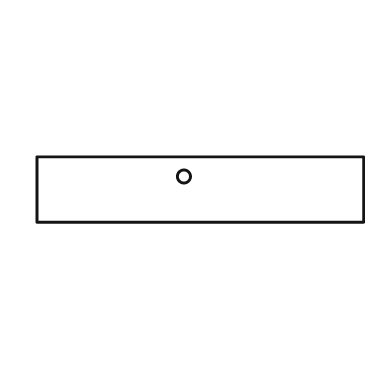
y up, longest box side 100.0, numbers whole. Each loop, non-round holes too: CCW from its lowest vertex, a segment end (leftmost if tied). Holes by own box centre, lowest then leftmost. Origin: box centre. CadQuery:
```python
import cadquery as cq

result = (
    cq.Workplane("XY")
    .moveTo(-50.0, -10.0)
    .lineTo(50.0, -10.0)
    .lineTo(50.0, 10.0)
    .lineTo(-50.0, 10.0)
    .close()
    .moveTo(-5.0, 4.0)
    .circle(2.0)
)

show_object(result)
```